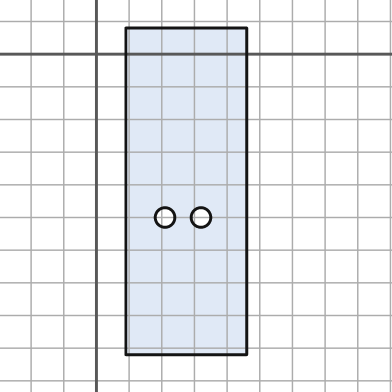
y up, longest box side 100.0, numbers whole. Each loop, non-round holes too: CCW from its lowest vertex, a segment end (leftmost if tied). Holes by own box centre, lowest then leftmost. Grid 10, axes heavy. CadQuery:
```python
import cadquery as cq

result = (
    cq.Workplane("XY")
    .moveTo(9.0, -92.0)
    .lineTo(46.0, -92.0)
    .lineTo(46.0, 8.0)
    .lineTo(9.0, 8.0)
    .close()
    .moveTo(21.0, -50.0)
    .circle(3.0)
    .moveTo(32.0, -50.0)
    .circle(3.0)
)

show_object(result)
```